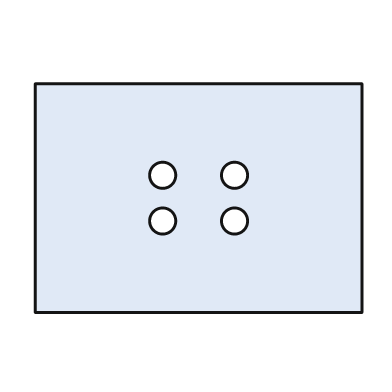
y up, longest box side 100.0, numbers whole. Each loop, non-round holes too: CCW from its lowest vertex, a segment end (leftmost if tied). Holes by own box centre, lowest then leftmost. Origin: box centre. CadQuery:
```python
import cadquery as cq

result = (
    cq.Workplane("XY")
    .moveTo(-50.0, -35.0)
    .lineTo(50.0, -35.0)
    .lineTo(50.0, 35.0)
    .lineTo(-50.0, 35.0)
    .close()
    .moveTo(-11.0, -7.0)
    .circle(4.0)
    .moveTo(11.0, -7.0)
    .circle(4.0)
    .moveTo(-11.0, 7.0)
    .circle(4.0)
    .moveTo(11.0, 7.0)
    .circle(4.0)
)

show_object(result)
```